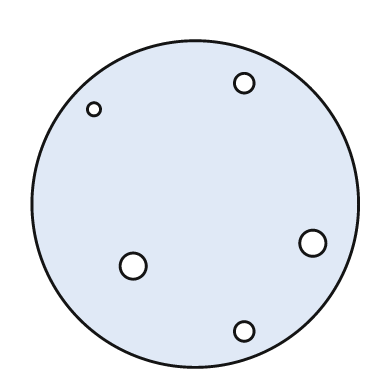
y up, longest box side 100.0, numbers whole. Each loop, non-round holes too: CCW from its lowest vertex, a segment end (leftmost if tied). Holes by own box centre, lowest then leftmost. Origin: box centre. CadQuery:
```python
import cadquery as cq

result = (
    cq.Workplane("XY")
    .moveTo(0.0, 0.0)
    .circle(50.0)
    .moveTo(15.0, -39.0)
    .circle(3.0)
    .moveTo(-19.0, -19.0)
    .circle(4.0)
    .moveTo(36.0, -12.0)
    .circle(4.0)
    .moveTo(-31.0, 29.0)
    .circle(2.0)
    .moveTo(15.0, 37.0)
    .circle(3.0)
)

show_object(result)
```